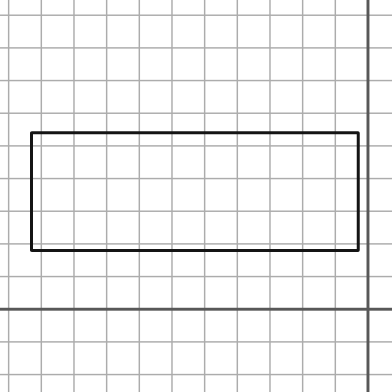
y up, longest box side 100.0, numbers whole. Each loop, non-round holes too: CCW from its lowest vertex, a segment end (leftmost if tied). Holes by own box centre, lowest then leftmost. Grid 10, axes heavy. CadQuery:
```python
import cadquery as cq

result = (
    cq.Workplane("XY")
    .moveTo(-103.0, 18.0)
    .lineTo(-3.0, 18.0)
    .lineTo(-3.0, 54.0)
    .lineTo(-103.0, 54.0)
    .close()
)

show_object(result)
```